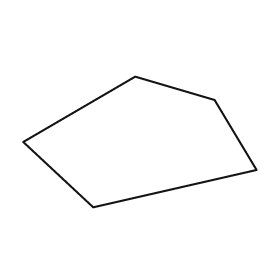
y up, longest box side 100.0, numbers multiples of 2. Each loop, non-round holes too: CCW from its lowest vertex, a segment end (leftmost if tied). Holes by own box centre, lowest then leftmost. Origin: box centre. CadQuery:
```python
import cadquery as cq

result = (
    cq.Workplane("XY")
    .moveTo(-20.0, -28.0)
    .lineTo(50.0, -12.0)
    .lineTo(32.0, 18.0)
    .lineTo(-2.0, 28.0)
    .lineTo(-50.0, 0.0)
    .close()
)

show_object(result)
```